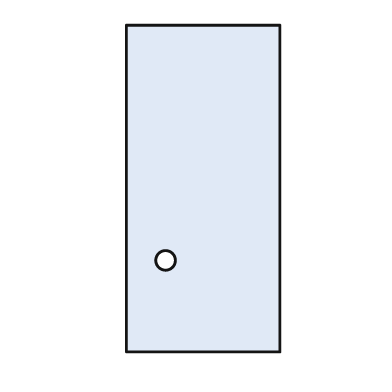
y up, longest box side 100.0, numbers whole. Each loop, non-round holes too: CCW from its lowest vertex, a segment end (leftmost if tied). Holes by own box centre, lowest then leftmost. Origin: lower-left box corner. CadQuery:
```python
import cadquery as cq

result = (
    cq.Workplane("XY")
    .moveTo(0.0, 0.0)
    .lineTo(47.0, 0.0)
    .lineTo(47.0, 100.0)
    .lineTo(0.0, 100.0)
    .close()
    .moveTo(12.0, 28.0)
    .circle(3.0)
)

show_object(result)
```